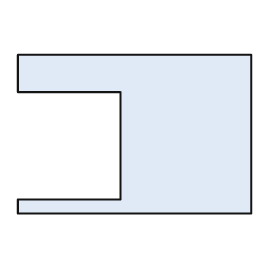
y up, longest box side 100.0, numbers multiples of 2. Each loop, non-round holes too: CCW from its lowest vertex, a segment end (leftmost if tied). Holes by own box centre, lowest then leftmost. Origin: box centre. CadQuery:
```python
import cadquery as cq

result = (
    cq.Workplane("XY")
    .moveTo(-50.0, -34.0)
    .lineTo(50.0, -34.0)
    .lineTo(50.0, 34.0)
    .lineTo(-50.0, 34.0)
    .lineTo(-50.0, 18.0)
    .lineTo(-6.0, 18.0)
    .lineTo(-6.0, -28.0)
    .lineTo(-50.0, -28.0)
    .close()
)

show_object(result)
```